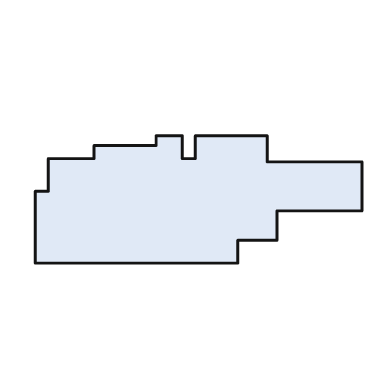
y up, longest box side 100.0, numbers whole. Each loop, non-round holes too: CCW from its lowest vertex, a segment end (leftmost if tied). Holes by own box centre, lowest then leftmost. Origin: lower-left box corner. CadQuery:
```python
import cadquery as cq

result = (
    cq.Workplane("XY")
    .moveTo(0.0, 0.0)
    .lineTo(62.0, 0.0)
    .lineTo(62.0, 7.0)
    .lineTo(74.0, 7.0)
    .lineTo(74.0, 16.0)
    .lineTo(100.0, 16.0)
    .lineTo(100.0, 31.0)
    .lineTo(71.0, 31.0)
    .lineTo(71.0, 39.0)
    .lineTo(49.0, 39.0)
    .lineTo(49.0, 32.0)
    .lineTo(45.0, 32.0)
    .lineTo(45.0, 39.0)
    .lineTo(37.0, 39.0)
    .lineTo(37.0, 36.0)
    .lineTo(18.0, 36.0)
    .lineTo(18.0, 32.0)
    .lineTo(4.0, 32.0)
    .lineTo(4.0, 22.0)
    .lineTo(0.0, 22.0)
    .close()
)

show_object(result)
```